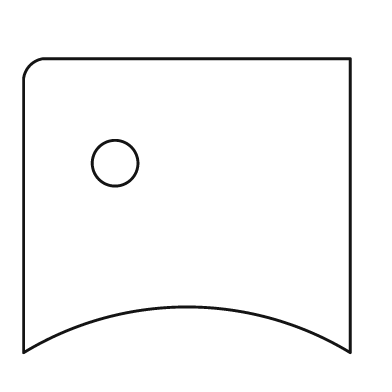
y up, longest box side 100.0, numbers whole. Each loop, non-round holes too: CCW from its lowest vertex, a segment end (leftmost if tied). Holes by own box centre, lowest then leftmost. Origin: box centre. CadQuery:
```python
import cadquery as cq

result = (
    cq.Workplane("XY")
    .moveTo(-50.0, -45.0)
    .threePointArc((0.0, -31.0), (50.0, -45.0))
    .lineTo(50.0, 45.0)
    .lineTo(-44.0, 45.0)
    .threePointArc((-48.0, 43.0), (-50.0, 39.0))
    .close()
    .moveTo(-22.0, 13.0)
    .circle(7.0)
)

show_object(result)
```